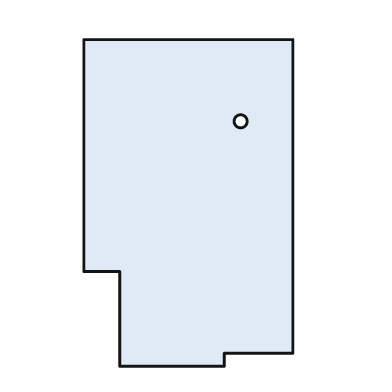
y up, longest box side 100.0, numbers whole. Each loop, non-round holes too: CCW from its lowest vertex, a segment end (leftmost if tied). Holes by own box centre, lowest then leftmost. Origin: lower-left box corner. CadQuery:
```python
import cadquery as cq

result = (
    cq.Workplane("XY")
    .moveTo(11.0, 0.0)
    .lineTo(43.0, 0.0)
    .lineTo(43.0, 4.0)
    .lineTo(64.0, 4.0)
    .lineTo(64.0, 100.0)
    .lineTo(0.0, 100.0)
    .lineTo(0.0, 29.0)
    .lineTo(11.0, 29.0)
    .close()
    .moveTo(48.0, 75.0)
    .circle(2.0)
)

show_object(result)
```